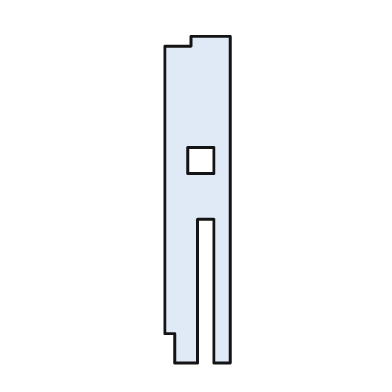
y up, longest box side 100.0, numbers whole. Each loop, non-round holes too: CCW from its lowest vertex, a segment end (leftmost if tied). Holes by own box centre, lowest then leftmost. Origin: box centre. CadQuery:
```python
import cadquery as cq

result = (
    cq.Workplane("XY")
    .moveTo(-7.0, -50.0)
    .lineTo(0.0, -50.0)
    .lineTo(0.0, -6.0)
    .lineTo(5.0, -6.0)
    .lineTo(5.0, -50.0)
    .lineTo(10.0, -50.0)
    .lineTo(10.0, 50.0)
    .lineTo(-2.0, 50.0)
    .lineTo(-2.0, 47.0)
    .lineTo(-10.0, 47.0)
    .lineTo(-10.0, -41.0)
    .lineTo(-7.0, -41.0)
    .close()
    .moveTo(-3.0, 8.0)
    .lineTo(5.0, 8.0)
    .lineTo(5.0, 16.0)
    .lineTo(-3.0, 16.0)
    .close()
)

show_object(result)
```